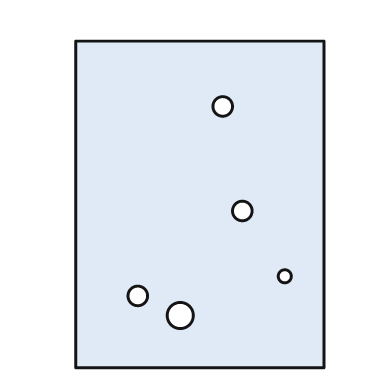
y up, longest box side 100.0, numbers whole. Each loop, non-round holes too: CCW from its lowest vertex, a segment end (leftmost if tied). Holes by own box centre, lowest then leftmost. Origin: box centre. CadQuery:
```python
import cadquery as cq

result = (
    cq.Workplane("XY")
    .moveTo(-38.0, -50.0)
    .lineTo(38.0, -50.0)
    .lineTo(38.0, 50.0)
    .lineTo(-38.0, 50.0)
    .close()
    .moveTo(-6.0, -34.0)
    .circle(4.0)
    .moveTo(-19.0, -28.0)
    .circle(3.0)
    .moveTo(26.0, -22.0)
    .circle(2.0)
    .moveTo(13.0, -2.0)
    .circle(3.0)
    .moveTo(7.0, 30.0)
    .circle(3.0)
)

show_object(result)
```